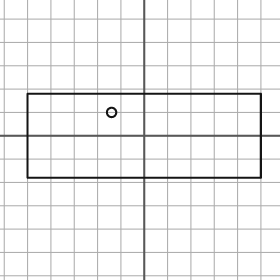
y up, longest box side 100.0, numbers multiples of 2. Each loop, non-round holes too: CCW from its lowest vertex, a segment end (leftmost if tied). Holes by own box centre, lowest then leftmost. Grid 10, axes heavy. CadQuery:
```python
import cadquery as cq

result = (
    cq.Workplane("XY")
    .moveTo(-50.0, -18.0)
    .lineTo(50.0, -18.0)
    .lineTo(50.0, 18.0)
    .lineTo(-50.0, 18.0)
    .close()
    .moveTo(-14.0, 10.0)
    .circle(2.0)
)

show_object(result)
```